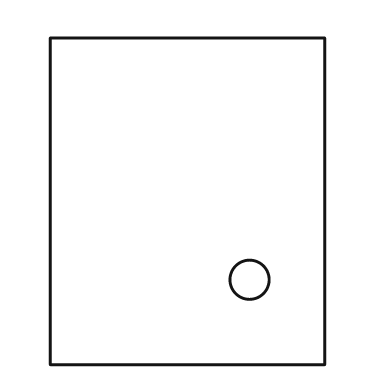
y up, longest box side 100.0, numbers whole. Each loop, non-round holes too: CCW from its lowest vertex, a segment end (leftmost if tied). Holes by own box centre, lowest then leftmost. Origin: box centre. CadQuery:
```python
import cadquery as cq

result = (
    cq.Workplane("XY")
    .moveTo(-42.0, -50.0)
    .lineTo(42.0, -50.0)
    .lineTo(42.0, 50.0)
    .lineTo(-42.0, 50.0)
    .close()
    .moveTo(19.0, -24.0)
    .circle(6.0)
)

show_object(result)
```